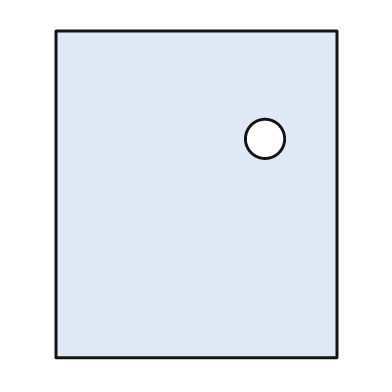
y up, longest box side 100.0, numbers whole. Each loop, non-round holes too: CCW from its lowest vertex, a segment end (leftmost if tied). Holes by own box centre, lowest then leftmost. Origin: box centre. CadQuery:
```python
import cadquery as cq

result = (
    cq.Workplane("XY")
    .moveTo(-43.0, -50.0)
    .lineTo(43.0, -50.0)
    .lineTo(43.0, 50.0)
    .lineTo(-43.0, 50.0)
    .close()
    .moveTo(21.0, 17.0)
    .circle(6.0)
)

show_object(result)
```